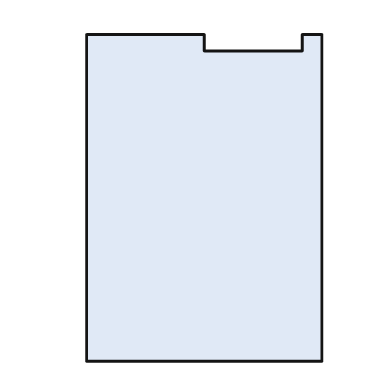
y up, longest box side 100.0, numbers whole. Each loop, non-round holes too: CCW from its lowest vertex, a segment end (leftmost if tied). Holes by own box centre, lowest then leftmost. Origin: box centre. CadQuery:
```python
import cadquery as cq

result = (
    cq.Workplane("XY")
    .moveTo(-36.0, -50.0)
    .lineTo(36.0, -50.0)
    .lineTo(36.0, 50.0)
    .lineTo(30.0, 50.0)
    .lineTo(30.0, 45.0)
    .lineTo(0.0, 45.0)
    .lineTo(0.0, 50.0)
    .lineTo(-36.0, 50.0)
    .close()
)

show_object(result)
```